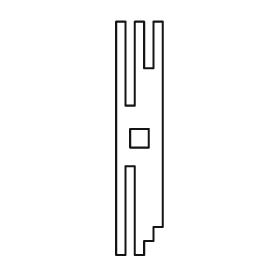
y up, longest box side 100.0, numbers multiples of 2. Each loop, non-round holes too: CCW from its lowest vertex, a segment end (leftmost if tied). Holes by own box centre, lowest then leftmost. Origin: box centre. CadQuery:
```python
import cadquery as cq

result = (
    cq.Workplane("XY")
    .moveTo(-10.0, -50.0)
    .lineTo(-6.0, -50.0)
    .lineTo(-6.0, -12.0)
    .lineTo(-2.0, -12.0)
    .lineTo(-2.0, -50.0)
    .lineTo(2.0, -50.0)
    .lineTo(2.0, -44.0)
    .lineTo(6.0, -44.0)
    .lineTo(6.0, -38.0)
    .lineTo(10.0, -38.0)
    .lineTo(10.0, 50.0)
    .lineTo(6.0, 50.0)
    .lineTo(6.0, 30.0)
    .lineTo(2.0, 30.0)
    .lineTo(2.0, 50.0)
    .lineTo(-2.0, 50.0)
    .lineTo(-2.0, 14.0)
    .lineTo(-6.0, 14.0)
    .lineTo(-6.0, 50.0)
    .lineTo(-10.0, 50.0)
    .close()
    .moveTo(-4.0, -4.0)
    .lineTo(4.0, -4.0)
    .lineTo(4.0, 4.0)
    .lineTo(-4.0, 4.0)
    .close()
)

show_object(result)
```